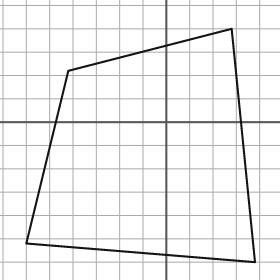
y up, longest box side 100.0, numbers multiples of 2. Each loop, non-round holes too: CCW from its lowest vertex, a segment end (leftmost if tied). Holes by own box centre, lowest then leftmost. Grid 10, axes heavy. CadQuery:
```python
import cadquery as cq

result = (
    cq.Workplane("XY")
    .moveTo(38.0, -60.0)
    .lineTo(28.0, 40.0)
    .lineTo(-42.0, 22.0)
    .lineTo(-60.0, -52.0)
    .close()
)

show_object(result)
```